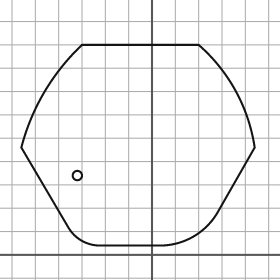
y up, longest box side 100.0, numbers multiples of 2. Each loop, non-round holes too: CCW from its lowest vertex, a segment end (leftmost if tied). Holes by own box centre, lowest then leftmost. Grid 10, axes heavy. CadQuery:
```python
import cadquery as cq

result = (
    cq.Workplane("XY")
    .moveTo(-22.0, 4.0)
    .lineTo(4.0, 4.0)
    .threePointArc((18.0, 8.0), (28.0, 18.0))
    .lineTo(44.0, 46.0)
    .threePointArc((36.0, 70.0), (20.0, 90.0))
    .lineTo(-30.0, 90.0)
    .threePointArc((-46.0, 70.0), (-56.0, 46.0))
    .lineTo(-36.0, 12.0)
    .threePointArc((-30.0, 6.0), (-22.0, 4.0))
    .close()
    .moveTo(-32.0, 34.0)
    .circle(2.0)
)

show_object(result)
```